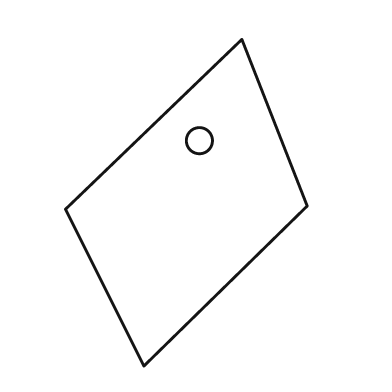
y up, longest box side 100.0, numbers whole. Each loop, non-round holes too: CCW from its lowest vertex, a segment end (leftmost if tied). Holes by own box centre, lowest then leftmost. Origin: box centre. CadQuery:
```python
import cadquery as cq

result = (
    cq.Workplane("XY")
    .moveTo(-13.0, -50.0)
    .lineTo(37.0, -1.0)
    .lineTo(17.0, 50.0)
    .lineTo(-37.0, -2.0)
    .close()
    .moveTo(4.0, 19.0)
    .circle(4.0)
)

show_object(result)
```